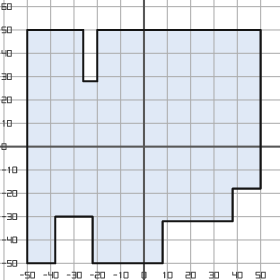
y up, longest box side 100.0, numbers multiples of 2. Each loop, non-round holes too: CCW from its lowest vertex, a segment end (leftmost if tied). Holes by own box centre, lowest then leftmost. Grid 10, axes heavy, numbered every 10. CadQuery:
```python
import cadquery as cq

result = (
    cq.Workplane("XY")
    .moveTo(-50.0, -50.0)
    .lineTo(-38.0, -50.0)
    .lineTo(-38.0, -30.0)
    .lineTo(-22.0, -30.0)
    .lineTo(-22.0, -50.0)
    .lineTo(8.0, -50.0)
    .lineTo(8.0, -32.0)
    .lineTo(38.0, -32.0)
    .lineTo(38.0, -18.0)
    .lineTo(50.0, -18.0)
    .lineTo(50.0, 50.0)
    .lineTo(-20.0, 50.0)
    .lineTo(-20.0, 28.0)
    .lineTo(-26.0, 28.0)
    .lineTo(-26.0, 50.0)
    .lineTo(-50.0, 50.0)
    .close()
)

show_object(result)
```